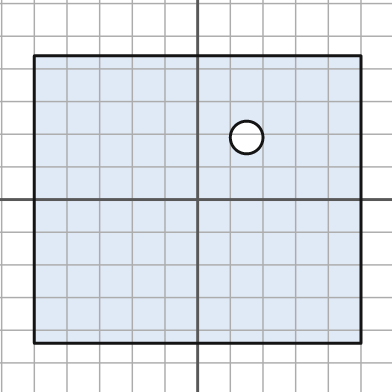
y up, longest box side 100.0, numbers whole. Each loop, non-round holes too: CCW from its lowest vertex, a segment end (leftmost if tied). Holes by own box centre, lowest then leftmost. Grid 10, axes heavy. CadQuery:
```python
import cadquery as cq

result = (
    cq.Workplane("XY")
    .moveTo(-50.0, -44.0)
    .lineTo(50.0, -44.0)
    .lineTo(50.0, 44.0)
    .lineTo(-50.0, 44.0)
    .close()
    .moveTo(15.0, 19.0)
    .circle(5.0)
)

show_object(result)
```